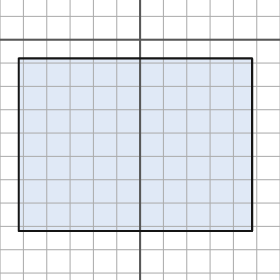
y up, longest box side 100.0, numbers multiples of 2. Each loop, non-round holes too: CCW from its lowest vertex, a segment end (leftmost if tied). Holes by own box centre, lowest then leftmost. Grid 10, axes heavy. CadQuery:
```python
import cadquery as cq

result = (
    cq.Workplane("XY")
    .moveTo(-52.0, -82.0)
    .lineTo(48.0, -82.0)
    .lineTo(48.0, -8.0)
    .lineTo(-52.0, -8.0)
    .close()
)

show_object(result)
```